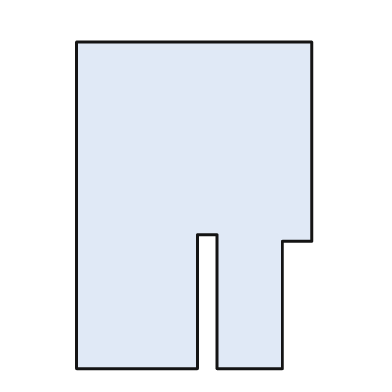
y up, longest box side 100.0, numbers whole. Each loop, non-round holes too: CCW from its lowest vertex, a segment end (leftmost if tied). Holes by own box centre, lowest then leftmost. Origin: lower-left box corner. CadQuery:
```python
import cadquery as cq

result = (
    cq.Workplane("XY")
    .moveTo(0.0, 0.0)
    .lineTo(37.0, 0.0)
    .lineTo(37.0, 41.0)
    .lineTo(43.0, 41.0)
    .lineTo(43.0, 0.0)
    .lineTo(63.0, 0.0)
    .lineTo(63.0, 39.0)
    .lineTo(72.0, 39.0)
    .lineTo(72.0, 100.0)
    .lineTo(0.0, 100.0)
    .close()
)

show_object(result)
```